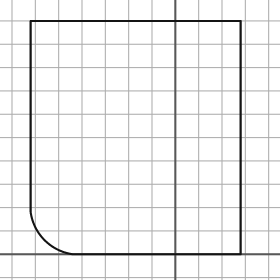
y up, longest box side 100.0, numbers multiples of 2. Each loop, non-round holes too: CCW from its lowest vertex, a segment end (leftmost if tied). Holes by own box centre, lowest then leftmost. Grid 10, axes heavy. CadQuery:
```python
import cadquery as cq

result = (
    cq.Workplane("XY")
    .moveTo(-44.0, 0.0)
    .lineTo(28.0, 0.0)
    .lineTo(28.0, 100.0)
    .lineTo(-62.0, 100.0)
    .lineTo(-62.0, 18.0)
    .threePointArc((-56.0, 6.0), (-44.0, 0.0))
    .close()
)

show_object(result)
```